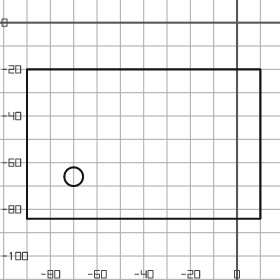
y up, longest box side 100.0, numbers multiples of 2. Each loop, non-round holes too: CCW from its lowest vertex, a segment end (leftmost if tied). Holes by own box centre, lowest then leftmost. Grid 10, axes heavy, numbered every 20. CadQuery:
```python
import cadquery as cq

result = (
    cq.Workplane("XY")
    .moveTo(-90.0, -84.0)
    .lineTo(10.0, -84.0)
    .lineTo(10.0, -20.0)
    .lineTo(-90.0, -20.0)
    .close()
    .moveTo(-70.0, -66.0)
    .circle(4.0)
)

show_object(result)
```